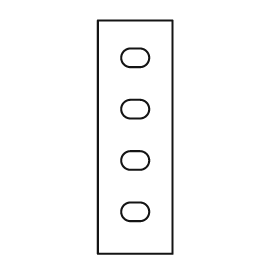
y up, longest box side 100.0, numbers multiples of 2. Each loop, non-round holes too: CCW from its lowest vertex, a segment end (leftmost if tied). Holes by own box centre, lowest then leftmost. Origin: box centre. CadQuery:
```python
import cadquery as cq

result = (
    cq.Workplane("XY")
    .moveTo(-16.0, -50.0)
    .lineTo(16.0, -50.0)
    .lineTo(16.0, 50.0)
    .lineTo(-16.0, 50.0)
    .close()
    .moveTo(-2.0, -36.0)
    .lineTo(2.0, -36.0)
    .threePointArc((6.0, -32.0), (2.0, -28.0))
    .lineTo(-2.0, -28.0)
    .threePointArc((-6.0, -32.0), (-2.0, -36.0))
    .close()
    .moveTo(-2.0, -14.0)
    .lineTo(2.0, -14.0)
    .threePointArc((6.0, -10.0), (2.0, -6.0))
    .lineTo(-2.0, -6.0)
    .threePointArc((-6.0, -10.0), (-2.0, -14.0))
    .close()
    .moveTo(-2.0, 8.0)
    .lineTo(2.0, 8.0)
    .threePointArc((6.0, 12.0), (2.0, 16.0))
    .lineTo(-2.0, 16.0)
    .threePointArc((-6.0, 12.0), (-2.0, 8.0))
    .close()
    .moveTo(-2.0, 30.0)
    .lineTo(2.0, 30.0)
    .threePointArc((6.0, 34.0), (2.0, 38.0))
    .lineTo(-2.0, 38.0)
    .threePointArc((-6.0, 34.0), (-2.0, 30.0))
    .close()
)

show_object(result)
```